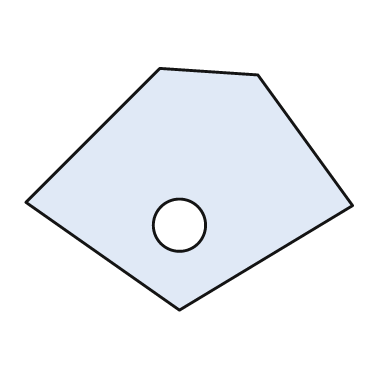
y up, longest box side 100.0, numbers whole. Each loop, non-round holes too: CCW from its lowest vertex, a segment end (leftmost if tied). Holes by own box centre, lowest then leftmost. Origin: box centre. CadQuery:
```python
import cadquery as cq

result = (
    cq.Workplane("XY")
    .moveTo(-3.0, -37.0)
    .lineTo(50.0, -5.0)
    .lineTo(21.0, 35.0)
    .lineTo(-9.0, 37.0)
    .lineTo(-50.0, -4.0)
    .close()
    .moveTo(-3.0, -11.0)
    .circle(8.0)
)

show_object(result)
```